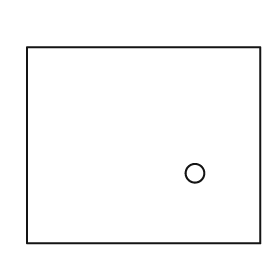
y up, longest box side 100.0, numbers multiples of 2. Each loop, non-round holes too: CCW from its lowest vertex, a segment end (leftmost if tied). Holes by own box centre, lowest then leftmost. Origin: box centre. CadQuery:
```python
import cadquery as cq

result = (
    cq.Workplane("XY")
    .moveTo(-50.0, -42.0)
    .lineTo(50.0, -42.0)
    .lineTo(50.0, 42.0)
    .lineTo(-50.0, 42.0)
    .close()
    .moveTo(22.0, -12.0)
    .circle(4.0)
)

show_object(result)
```